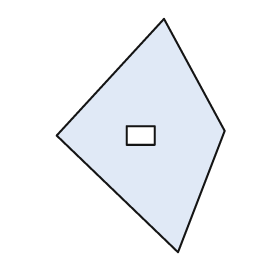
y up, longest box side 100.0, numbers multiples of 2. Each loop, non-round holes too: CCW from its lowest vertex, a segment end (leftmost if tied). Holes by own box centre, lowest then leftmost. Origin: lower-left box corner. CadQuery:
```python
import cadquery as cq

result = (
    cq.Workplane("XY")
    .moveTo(52.0, 0.0)
    .lineTo(72.0, 52.0)
    .lineTo(46.0, 100.0)
    .lineTo(0.0, 50.0)
    .close()
    .moveTo(30.0, 46.0)
    .lineTo(42.0, 46.0)
    .lineTo(42.0, 54.0)
    .lineTo(30.0, 54.0)
    .close()
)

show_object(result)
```